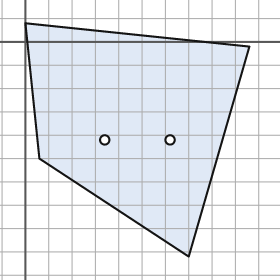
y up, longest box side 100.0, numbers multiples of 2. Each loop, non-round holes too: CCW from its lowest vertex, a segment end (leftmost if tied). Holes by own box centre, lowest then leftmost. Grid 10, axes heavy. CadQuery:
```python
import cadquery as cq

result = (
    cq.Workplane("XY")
    .moveTo(70.0, -92.0)
    .lineTo(96.0, -2.0)
    .lineTo(0.0, 8.0)
    .lineTo(6.0, -50.0)
    .close()
    .moveTo(34.0, -42.0)
    .circle(2.0)
    .moveTo(62.0, -42.0)
    .circle(2.0)
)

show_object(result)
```